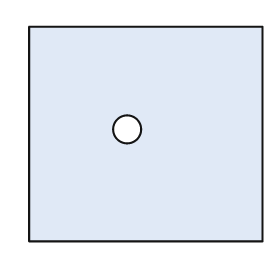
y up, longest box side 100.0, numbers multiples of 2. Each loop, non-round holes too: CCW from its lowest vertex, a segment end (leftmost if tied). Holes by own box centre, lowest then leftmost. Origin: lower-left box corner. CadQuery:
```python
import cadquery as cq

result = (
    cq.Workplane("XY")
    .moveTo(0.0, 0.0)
    .lineTo(100.0, 0.0)
    .lineTo(100.0, 92.0)
    .lineTo(0.0, 92.0)
    .close()
    .moveTo(42.0, 48.0)
    .circle(6.0)
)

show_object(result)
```